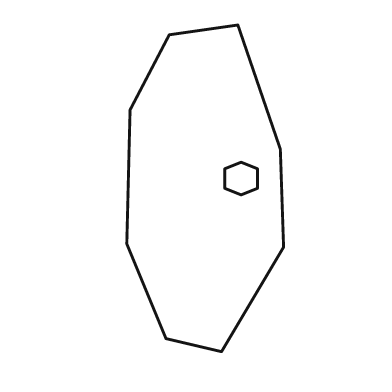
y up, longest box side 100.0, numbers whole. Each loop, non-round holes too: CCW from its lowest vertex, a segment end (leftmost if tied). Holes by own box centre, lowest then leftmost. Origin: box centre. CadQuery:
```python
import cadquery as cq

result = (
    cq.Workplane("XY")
    .moveTo(5.0, -50.0)
    .lineTo(24.0, -18.0)
    .lineTo(23.0, 12.0)
    .lineTo(10.0, 50.0)
    .lineTo(-11.0, 47.0)
    .lineTo(-23.0, 24.0)
    .lineTo(-24.0, -17.0)
    .lineTo(-12.0, -46.0)
    .close()
    .moveTo(11.0, -2.0)
    .lineTo(16.0, 0.0)
    .lineTo(16.0, 6.0)
    .lineTo(11.0, 8.0)
    .lineTo(6.0, 6.0)
    .lineTo(6.0, 0.0)
    .close()
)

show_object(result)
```